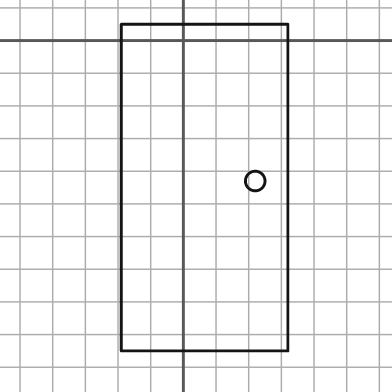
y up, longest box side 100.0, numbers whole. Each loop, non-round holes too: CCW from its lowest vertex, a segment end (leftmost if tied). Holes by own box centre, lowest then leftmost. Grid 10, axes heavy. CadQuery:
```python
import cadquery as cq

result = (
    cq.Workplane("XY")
    .moveTo(-19.0, -95.0)
    .lineTo(32.0, -95.0)
    .lineTo(32.0, 5.0)
    .lineTo(-19.0, 5.0)
    .close()
    .moveTo(22.0, -43.0)
    .circle(3.0)
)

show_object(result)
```